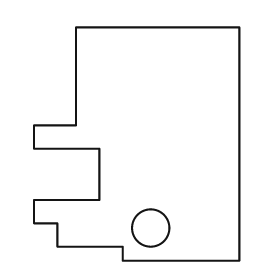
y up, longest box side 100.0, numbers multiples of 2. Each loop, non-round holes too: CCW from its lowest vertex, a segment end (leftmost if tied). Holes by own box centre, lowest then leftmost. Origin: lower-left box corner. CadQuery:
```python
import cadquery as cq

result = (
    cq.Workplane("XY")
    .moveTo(38.0, 0.0)
    .lineTo(88.0, 0.0)
    .lineTo(88.0, 100.0)
    .lineTo(18.0, 100.0)
    .lineTo(18.0, 58.0)
    .lineTo(0.0, 58.0)
    .lineTo(0.0, 48.0)
    .lineTo(28.0, 48.0)
    .lineTo(28.0, 26.0)
    .lineTo(0.0, 26.0)
    .lineTo(0.0, 16.0)
    .lineTo(10.0, 16.0)
    .lineTo(10.0, 6.0)
    .lineTo(38.0, 6.0)
    .close()
    .moveTo(50.0, 14.0)
    .circle(8.0)
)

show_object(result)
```